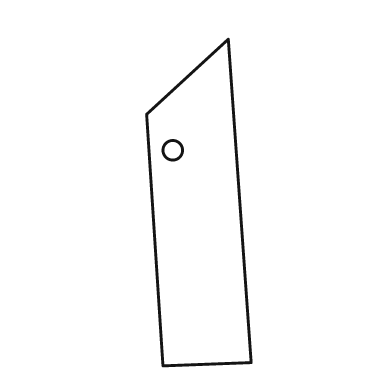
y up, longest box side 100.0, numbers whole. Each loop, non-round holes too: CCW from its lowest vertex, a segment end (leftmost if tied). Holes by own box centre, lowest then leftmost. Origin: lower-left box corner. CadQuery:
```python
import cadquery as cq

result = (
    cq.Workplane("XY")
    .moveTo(5.0, 0.0)
    .lineTo(32.0, 1.0)
    .lineTo(25.0, 100.0)
    .lineTo(0.0, 77.0)
    .close()
    .moveTo(8.0, 66.0)
    .circle(3.0)
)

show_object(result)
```